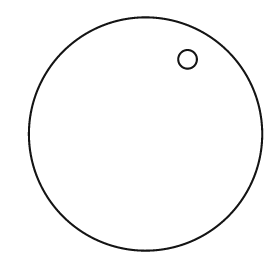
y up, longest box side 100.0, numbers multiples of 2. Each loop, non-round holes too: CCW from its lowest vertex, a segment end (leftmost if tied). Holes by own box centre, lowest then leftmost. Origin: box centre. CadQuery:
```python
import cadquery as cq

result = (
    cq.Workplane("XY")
    .moveTo(0.0, 0.0)
    .circle(50.0)
    .moveTo(18.0, 32.0)
    .circle(4.0)
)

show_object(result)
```